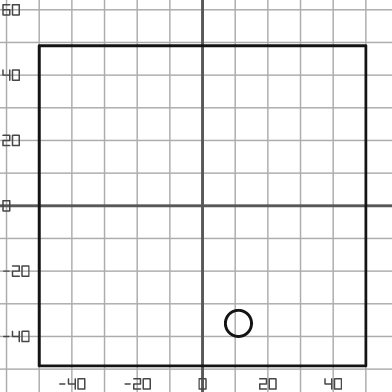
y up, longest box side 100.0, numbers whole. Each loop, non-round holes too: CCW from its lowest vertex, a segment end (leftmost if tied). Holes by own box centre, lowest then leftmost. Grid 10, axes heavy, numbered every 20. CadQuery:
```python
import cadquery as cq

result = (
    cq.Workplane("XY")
    .moveTo(-50.0, -49.0)
    .lineTo(50.0, -49.0)
    .lineTo(50.0, 49.0)
    .lineTo(-50.0, 49.0)
    .close()
    .moveTo(11.0, -36.0)
    .circle(4.0)
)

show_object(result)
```